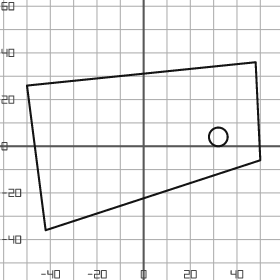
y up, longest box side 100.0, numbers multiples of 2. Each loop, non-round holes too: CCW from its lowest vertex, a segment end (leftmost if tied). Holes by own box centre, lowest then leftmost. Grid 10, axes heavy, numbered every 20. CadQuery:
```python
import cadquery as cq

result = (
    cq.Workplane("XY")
    .moveTo(-42.0, -36.0)
    .lineTo(50.0, -6.0)
    .lineTo(48.0, 36.0)
    .lineTo(-50.0, 26.0)
    .close()
    .moveTo(32.0, 4.0)
    .circle(4.0)
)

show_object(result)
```